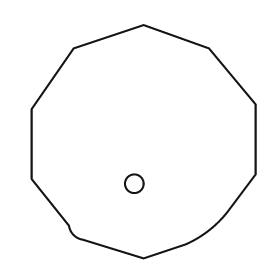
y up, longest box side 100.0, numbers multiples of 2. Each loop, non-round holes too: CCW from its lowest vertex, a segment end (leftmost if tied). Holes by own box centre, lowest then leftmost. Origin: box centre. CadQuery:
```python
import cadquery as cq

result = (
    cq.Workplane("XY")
    .moveTo(0.0, -50.0)
    .lineTo(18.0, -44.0)
    .threePointArc((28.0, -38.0), (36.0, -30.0))
    .lineTo(48.0, -14.0)
    .lineTo(48.0, 16.0)
    .lineTo(28.0, 40.0)
    .lineTo(0.0, 50.0)
    .lineTo(-30.0, 40.0)
    .lineTo(-48.0, 14.0)
    .lineTo(-48.0, -16.0)
    .lineTo(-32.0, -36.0)
    .threePointArc((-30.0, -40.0), (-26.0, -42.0))
    .close()
    .moveTo(-4.0, -18.0)
    .circle(4.0)
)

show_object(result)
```